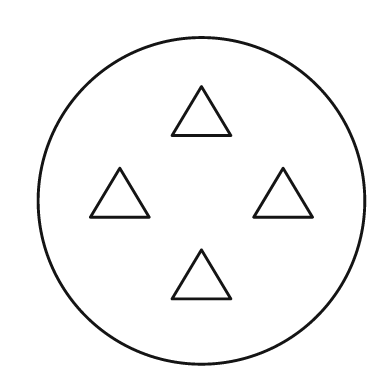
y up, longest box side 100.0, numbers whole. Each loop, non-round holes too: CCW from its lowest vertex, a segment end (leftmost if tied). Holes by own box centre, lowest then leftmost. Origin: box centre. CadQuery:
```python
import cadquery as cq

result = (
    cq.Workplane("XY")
    .moveTo(0.0, 0.0)
    .circle(50.0)
    .moveTo(-9.0, -30.0)
    .lineTo(9.0, -30.0)
    .lineTo(0.0, -15.0)
    .close()
    .moveTo(-34.0, -5.0)
    .lineTo(-16.0, -5.0)
    .lineTo(-25.0, 10.0)
    .close()
    .moveTo(16.0, -5.0)
    .lineTo(34.0, -5.0)
    .lineTo(25.0, 10.0)
    .close()
    .moveTo(-9.0, 20.0)
    .lineTo(9.0, 20.0)
    .lineTo(0.0, 35.0)
    .close()
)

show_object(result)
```